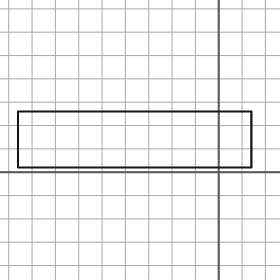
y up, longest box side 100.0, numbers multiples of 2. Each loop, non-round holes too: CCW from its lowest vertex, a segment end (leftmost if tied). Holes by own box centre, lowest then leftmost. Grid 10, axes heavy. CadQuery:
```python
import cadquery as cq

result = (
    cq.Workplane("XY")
    .moveTo(-86.0, 2.0)
    .lineTo(14.0, 2.0)
    .lineTo(14.0, 26.0)
    .lineTo(-86.0, 26.0)
    .close()
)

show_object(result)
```